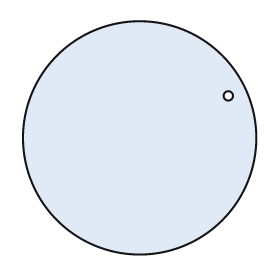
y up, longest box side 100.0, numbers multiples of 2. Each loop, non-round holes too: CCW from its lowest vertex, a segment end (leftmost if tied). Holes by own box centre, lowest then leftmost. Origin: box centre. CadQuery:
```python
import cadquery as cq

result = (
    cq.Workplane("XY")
    .moveTo(0.0, 0.0)
    .circle(50.0)
    .moveTo(38.0, 18.0)
    .circle(2.0)
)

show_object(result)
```